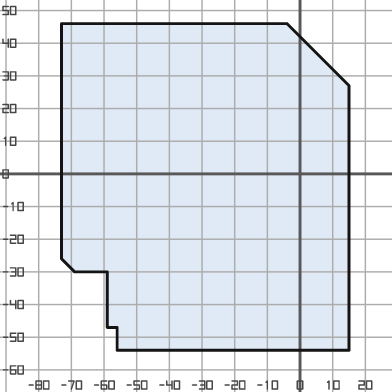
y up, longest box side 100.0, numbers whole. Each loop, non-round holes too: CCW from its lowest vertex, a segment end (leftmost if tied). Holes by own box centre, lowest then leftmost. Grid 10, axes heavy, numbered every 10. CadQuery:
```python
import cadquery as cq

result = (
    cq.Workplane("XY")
    .moveTo(-56.0, -54.0)
    .lineTo(15.0, -54.0)
    .lineTo(15.0, 27.0)
    .lineTo(-4.0, 46.0)
    .lineTo(-73.0, 46.0)
    .lineTo(-73.0, -26.0)
    .lineTo(-69.0, -30.0)
    .lineTo(-59.0, -30.0)
    .lineTo(-59.0, -47.0)
    .lineTo(-56.0, -47.0)
    .close()
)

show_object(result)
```